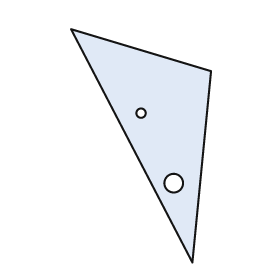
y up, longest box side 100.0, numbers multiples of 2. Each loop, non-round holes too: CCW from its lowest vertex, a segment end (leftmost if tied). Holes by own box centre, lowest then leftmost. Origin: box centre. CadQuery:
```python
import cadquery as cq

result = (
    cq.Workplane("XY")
    .moveTo(22.0, -50.0)
    .lineTo(30.0, 32.0)
    .lineTo(-30.0, 50.0)
    .close()
    .moveTo(14.0, -16.0)
    .circle(4.0)
    .moveTo(0.0, 14.0)
    .circle(2.0)
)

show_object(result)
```